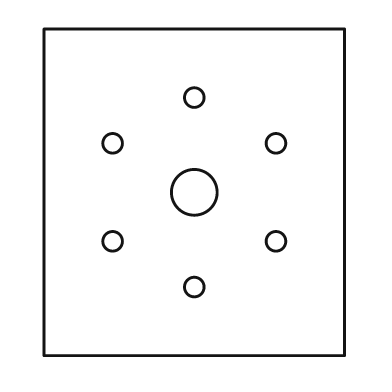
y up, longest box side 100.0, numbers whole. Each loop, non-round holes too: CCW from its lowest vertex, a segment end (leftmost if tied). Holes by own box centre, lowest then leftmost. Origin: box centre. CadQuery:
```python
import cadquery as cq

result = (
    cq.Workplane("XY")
    .moveTo(-46.0, -50.0)
    .lineTo(46.0, -50.0)
    .lineTo(46.0, 50.0)
    .lineTo(-46.0, 50.0)
    .close()
    .moveTo(0.0, -29.0)
    .circle(3.0)
    .moveTo(-25.0, -15.0)
    .circle(3.0)
    .moveTo(25.0, -15.0)
    .circle(3.0)
    .moveTo(0.0, 0.0)
    .circle(7.0)
    .moveTo(-25.0, 15.0)
    .circle(3.0)
    .moveTo(25.0, 15.0)
    .circle(3.0)
    .moveTo(0.0, 29.0)
    .circle(3.0)
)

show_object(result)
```